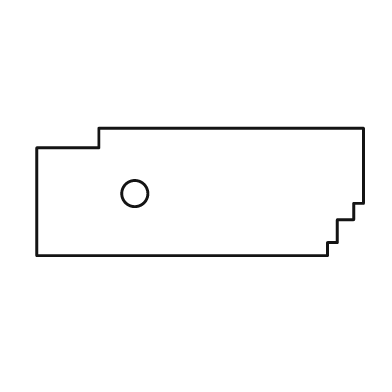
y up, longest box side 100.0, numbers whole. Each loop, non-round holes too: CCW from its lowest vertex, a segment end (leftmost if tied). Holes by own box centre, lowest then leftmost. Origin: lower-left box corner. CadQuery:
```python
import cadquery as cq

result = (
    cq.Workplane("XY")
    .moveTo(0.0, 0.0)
    .lineTo(89.0, 0.0)
    .lineTo(89.0, 4.0)
    .lineTo(92.0, 4.0)
    .lineTo(92.0, 11.0)
    .lineTo(97.0, 11.0)
    .lineTo(97.0, 16.0)
    .lineTo(100.0, 16.0)
    .lineTo(100.0, 39.0)
    .lineTo(19.0, 39.0)
    .lineTo(19.0, 33.0)
    .lineTo(0.0, 33.0)
    .close()
    .moveTo(30.0, 19.0)
    .circle(4.0)
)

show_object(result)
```